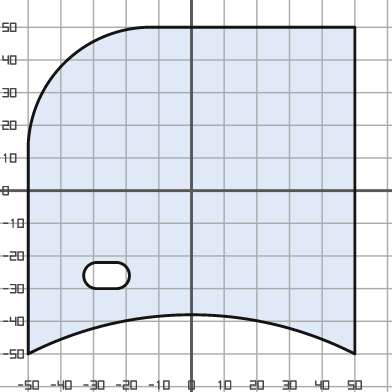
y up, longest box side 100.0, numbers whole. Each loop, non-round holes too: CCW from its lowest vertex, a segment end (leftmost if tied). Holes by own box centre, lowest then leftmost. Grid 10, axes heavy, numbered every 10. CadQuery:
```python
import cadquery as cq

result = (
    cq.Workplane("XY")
    .moveTo(-50.0, -50.0)
    .threePointArc((0.0, -38.0), (50.0, -50.0))
    .lineTo(50.0, 50.0)
    .lineTo(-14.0, 50.0)
    .threePointArc((-39.0, 39.0), (-50.0, 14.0))
    .close()
    .moveTo(-29.0, -30.0)
    .lineTo(-23.0, -30.0)
    .threePointArc((-19.0, -26.0), (-23.0, -22.0))
    .lineTo(-29.0, -22.0)
    .threePointArc((-33.0, -26.0), (-29.0, -30.0))
    .close()
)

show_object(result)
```